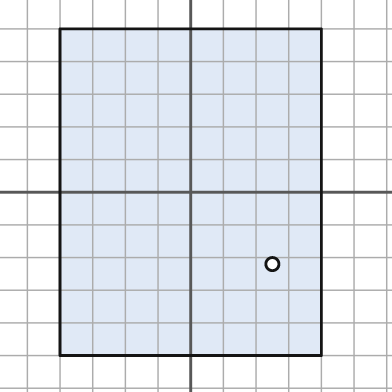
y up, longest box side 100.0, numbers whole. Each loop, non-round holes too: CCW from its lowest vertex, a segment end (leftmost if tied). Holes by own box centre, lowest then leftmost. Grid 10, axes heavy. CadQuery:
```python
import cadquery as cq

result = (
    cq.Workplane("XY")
    .moveTo(-40.0, -50.0)
    .lineTo(40.0, -50.0)
    .lineTo(40.0, 50.0)
    .lineTo(-40.0, 50.0)
    .close()
    .moveTo(25.0, -22.0)
    .circle(2.0)
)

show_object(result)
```